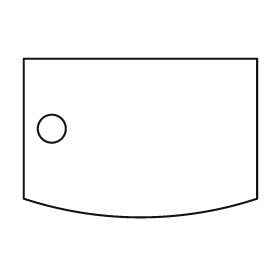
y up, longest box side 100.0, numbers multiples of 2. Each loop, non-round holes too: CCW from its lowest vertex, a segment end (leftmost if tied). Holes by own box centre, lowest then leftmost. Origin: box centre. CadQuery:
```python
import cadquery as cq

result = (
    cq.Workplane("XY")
    .moveTo(-50.0, -26.0)
    .threePointArc((0.0, -34.0), (50.0, -26.0))
    .lineTo(50.0, 34.0)
    .lineTo(-50.0, 34.0)
    .close()
    .moveTo(-38.0, 4.0)
    .circle(6.0)
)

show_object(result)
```